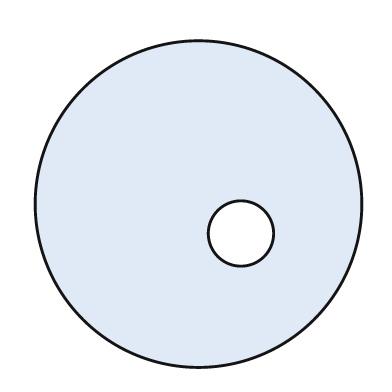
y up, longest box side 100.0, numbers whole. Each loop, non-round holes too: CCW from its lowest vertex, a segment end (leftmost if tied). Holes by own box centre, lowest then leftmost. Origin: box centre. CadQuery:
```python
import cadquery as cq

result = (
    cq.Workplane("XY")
    .moveTo(0.0, 0.0)
    .circle(50.0)
    .moveTo(13.0, -9.0)
    .circle(10.0)
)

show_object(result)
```